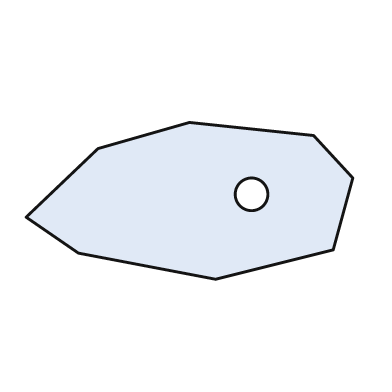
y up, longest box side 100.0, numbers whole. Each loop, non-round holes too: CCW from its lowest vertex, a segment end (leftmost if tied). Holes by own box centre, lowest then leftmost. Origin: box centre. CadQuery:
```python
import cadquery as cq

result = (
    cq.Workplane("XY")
    .moveTo(8.0, -24.0)
    .lineTo(44.0, -15.0)
    .lineTo(50.0, 7.0)
    .lineTo(38.0, 20.0)
    .lineTo(0.0, 24.0)
    .lineTo(-28.0, 16.0)
    .lineTo(-50.0, -5.0)
    .lineTo(-34.0, -16.0)
    .close()
    .moveTo(19.0, 2.0)
    .circle(5.0)
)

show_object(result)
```